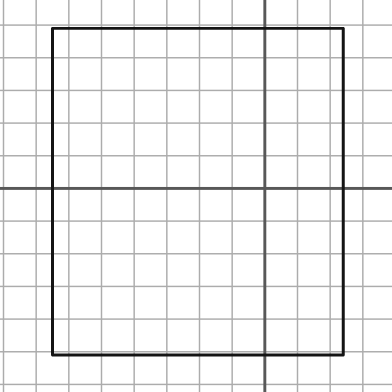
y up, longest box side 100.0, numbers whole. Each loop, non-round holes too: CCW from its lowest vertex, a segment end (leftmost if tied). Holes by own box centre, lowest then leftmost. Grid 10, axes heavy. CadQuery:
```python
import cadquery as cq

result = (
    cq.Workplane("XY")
    .moveTo(-65.0, -51.0)
    .lineTo(24.0, -51.0)
    .lineTo(24.0, 49.0)
    .lineTo(-65.0, 49.0)
    .close()
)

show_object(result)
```